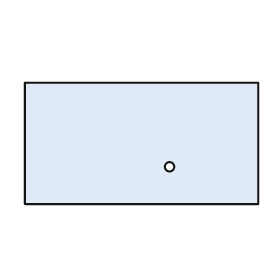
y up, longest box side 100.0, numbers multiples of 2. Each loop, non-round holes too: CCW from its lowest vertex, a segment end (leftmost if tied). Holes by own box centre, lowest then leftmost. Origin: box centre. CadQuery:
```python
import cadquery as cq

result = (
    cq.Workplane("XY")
    .moveTo(-50.0, -26.0)
    .lineTo(50.0, -26.0)
    .lineTo(50.0, 26.0)
    .lineTo(-50.0, 26.0)
    .close()
    .moveTo(12.0, -10.0)
    .circle(2.0)
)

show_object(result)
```